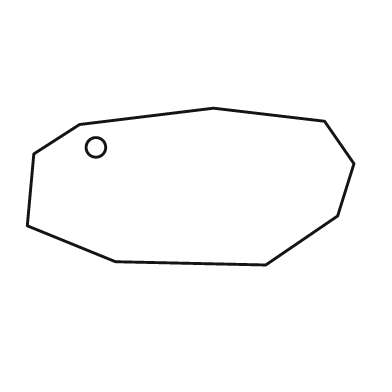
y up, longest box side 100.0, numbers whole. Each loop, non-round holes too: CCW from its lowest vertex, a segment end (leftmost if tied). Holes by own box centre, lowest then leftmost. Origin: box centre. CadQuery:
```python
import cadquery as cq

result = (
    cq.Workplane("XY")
    .moveTo(23.0, -24.0)
    .lineTo(45.0, -9.0)
    .lineTo(50.0, 7.0)
    .lineTo(41.0, 20.0)
    .lineTo(7.0, 24.0)
    .lineTo(-34.0, 19.0)
    .lineTo(-48.0, 10.0)
    .lineTo(-50.0, -12.0)
    .lineTo(-23.0, -23.0)
    .close()
    .moveTo(-29.0, 12.0)
    .circle(3.0)
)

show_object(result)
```